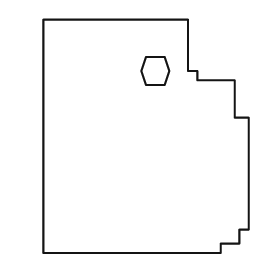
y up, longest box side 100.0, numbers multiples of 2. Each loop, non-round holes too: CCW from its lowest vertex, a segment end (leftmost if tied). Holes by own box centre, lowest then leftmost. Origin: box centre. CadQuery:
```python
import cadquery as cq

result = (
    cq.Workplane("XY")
    .moveTo(-44.0, -50.0)
    .lineTo(32.0, -50.0)
    .lineTo(32.0, -46.0)
    .lineTo(40.0, -46.0)
    .lineTo(40.0, -40.0)
    .lineTo(44.0, -40.0)
    .lineTo(44.0, 8.0)
    .lineTo(38.0, 8.0)
    .lineTo(38.0, 24.0)
    .lineTo(22.0, 24.0)
    .lineTo(22.0, 28.0)
    .lineTo(18.0, 28.0)
    .lineTo(18.0, 50.0)
    .lineTo(-44.0, 50.0)
    .close()
    .moveTo(0.0, 22.0)
    .lineTo(8.0, 22.0)
    .lineTo(10.0, 28.0)
    .lineTo(8.0, 34.0)
    .lineTo(0.0, 34.0)
    .lineTo(-2.0, 28.0)
    .close()
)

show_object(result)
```